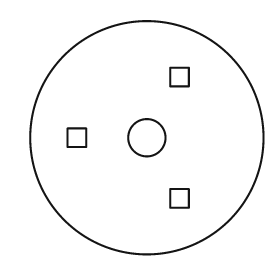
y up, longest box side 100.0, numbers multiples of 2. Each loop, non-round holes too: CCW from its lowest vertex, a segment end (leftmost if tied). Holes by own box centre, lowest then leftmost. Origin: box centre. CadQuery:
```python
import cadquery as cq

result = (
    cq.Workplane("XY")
    .moveTo(0.0, 0.0)
    .circle(50.0)
    .moveTo(10.0, -30.0)
    .lineTo(18.0, -30.0)
    .lineTo(18.0, -22.0)
    .lineTo(10.0, -22.0)
    .close()
    .moveTo(-34.0, -4.0)
    .lineTo(-26.0, -4.0)
    .lineTo(-26.0, 4.0)
    .lineTo(-34.0, 4.0)
    .close()
    .moveTo(0.0, 0.0)
    .circle(8.0)
    .moveTo(10.0, 22.0)
    .lineTo(18.0, 22.0)
    .lineTo(18.0, 30.0)
    .lineTo(10.0, 30.0)
    .close()
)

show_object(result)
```